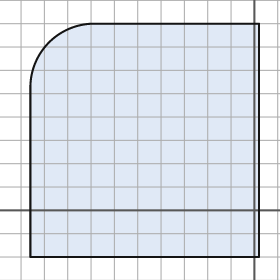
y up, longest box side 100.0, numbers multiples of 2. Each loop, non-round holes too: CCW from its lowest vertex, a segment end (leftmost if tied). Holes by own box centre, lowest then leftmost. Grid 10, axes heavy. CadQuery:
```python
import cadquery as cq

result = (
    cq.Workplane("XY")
    .moveTo(-96.0, -20.0)
    .lineTo(2.0, -20.0)
    .lineTo(2.0, 80.0)
    .lineTo(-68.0, 80.0)
    .threePointArc((-88.0, 72.0), (-96.0, 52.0))
    .close()
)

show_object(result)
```